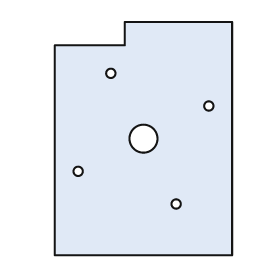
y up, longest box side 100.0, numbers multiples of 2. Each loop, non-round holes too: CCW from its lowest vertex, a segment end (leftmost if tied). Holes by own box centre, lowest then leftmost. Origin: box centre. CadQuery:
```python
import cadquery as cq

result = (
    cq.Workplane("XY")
    .moveTo(-38.0, -50.0)
    .lineTo(38.0, -50.0)
    .lineTo(38.0, 50.0)
    .lineTo(-8.0, 50.0)
    .lineTo(-8.0, 40.0)
    .lineTo(-38.0, 40.0)
    .close()
    .moveTo(14.0, -28.0)
    .circle(2.0)
    .moveTo(-28.0, -14.0)
    .circle(2.0)
    .moveTo(0.0, 0.0)
    .circle(6.0)
    .moveTo(28.0, 14.0)
    .circle(2.0)
    .moveTo(-14.0, 28.0)
    .circle(2.0)
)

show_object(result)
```